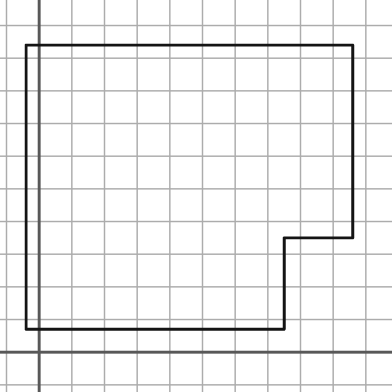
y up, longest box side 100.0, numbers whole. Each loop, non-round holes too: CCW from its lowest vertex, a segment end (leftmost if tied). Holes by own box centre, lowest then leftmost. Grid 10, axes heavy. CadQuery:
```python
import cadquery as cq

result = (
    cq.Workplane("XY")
    .moveTo(-4.0, 7.0)
    .lineTo(75.0, 7.0)
    .lineTo(75.0, 35.0)
    .lineTo(96.0, 35.0)
    .lineTo(96.0, 94.0)
    .lineTo(-4.0, 94.0)
    .close()
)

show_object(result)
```